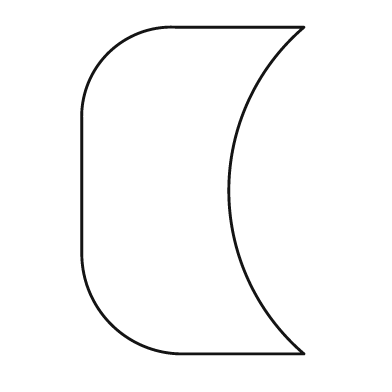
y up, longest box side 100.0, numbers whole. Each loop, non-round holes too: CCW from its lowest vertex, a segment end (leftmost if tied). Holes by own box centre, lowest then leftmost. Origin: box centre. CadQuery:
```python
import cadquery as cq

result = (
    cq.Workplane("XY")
    .moveTo(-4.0, -50.0)
    .lineTo(34.0, -50.0)
    .threePointArc((11.0, 0.0), (34.0, 50.0))
    .lineTo(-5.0, 50.0)
    .threePointArc((-26.0, 42.0), (-34.0, 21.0))
    .lineTo(-34.0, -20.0)
    .threePointArc((-25.0, -41.0), (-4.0, -50.0))
    .close()
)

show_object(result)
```